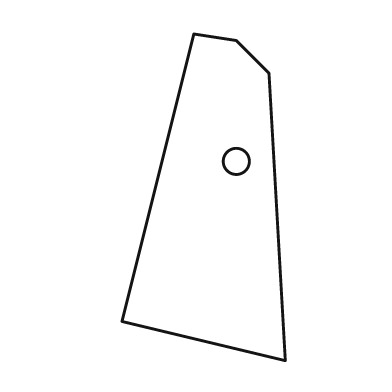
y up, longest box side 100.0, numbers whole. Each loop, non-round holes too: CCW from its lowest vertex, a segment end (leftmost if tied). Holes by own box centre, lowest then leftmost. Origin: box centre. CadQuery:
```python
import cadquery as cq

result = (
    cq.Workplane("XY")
    .moveTo(25.0, -50.0)
    .lineTo(20.0, 38.0)
    .lineTo(10.0, 48.0)
    .lineTo(-3.0, 50.0)
    .lineTo(-25.0, -38.0)
    .close()
    .moveTo(10.0, 11.0)
    .circle(4.0)
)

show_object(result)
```